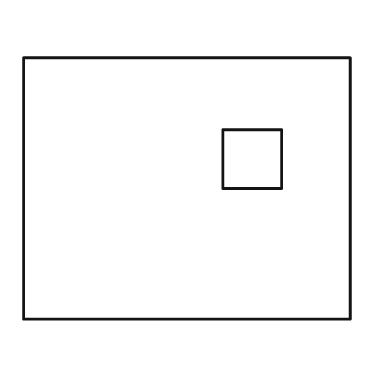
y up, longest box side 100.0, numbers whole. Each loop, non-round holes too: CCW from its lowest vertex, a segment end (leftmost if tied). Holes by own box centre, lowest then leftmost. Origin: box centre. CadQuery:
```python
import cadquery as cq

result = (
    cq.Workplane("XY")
    .moveTo(-50.0, -40.0)
    .lineTo(50.0, -40.0)
    .lineTo(50.0, 40.0)
    .lineTo(-50.0, 40.0)
    .close()
    .moveTo(11.0, 0.0)
    .lineTo(29.0, 0.0)
    .lineTo(29.0, 18.0)
    .lineTo(11.0, 18.0)
    .close()
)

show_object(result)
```